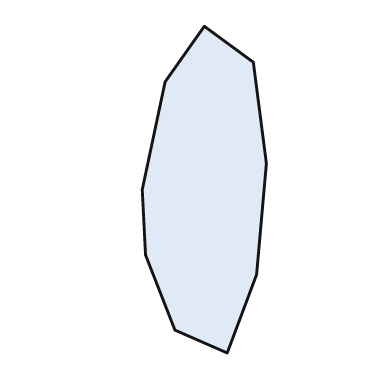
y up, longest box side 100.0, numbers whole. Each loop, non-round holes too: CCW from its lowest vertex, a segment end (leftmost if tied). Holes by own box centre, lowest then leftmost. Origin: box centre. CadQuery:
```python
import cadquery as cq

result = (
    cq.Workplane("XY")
    .moveTo(7.0, -50.0)
    .lineTo(16.0, -26.0)
    .lineTo(19.0, 8.0)
    .lineTo(15.0, 39.0)
    .lineTo(0.0, 50.0)
    .lineTo(-12.0, 33.0)
    .lineTo(-19.0, 0.0)
    .lineTo(-18.0, -20.0)
    .lineTo(-9.0, -43.0)
    .close()
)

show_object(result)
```